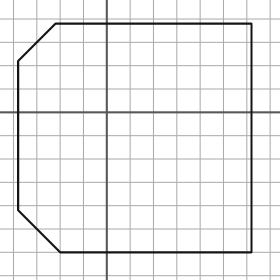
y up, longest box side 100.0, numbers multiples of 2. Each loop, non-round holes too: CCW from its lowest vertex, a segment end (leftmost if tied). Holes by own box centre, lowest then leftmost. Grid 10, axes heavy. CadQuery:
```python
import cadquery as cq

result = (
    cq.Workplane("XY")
    .moveTo(-20.0, -60.0)
    .lineTo(62.0, -60.0)
    .lineTo(62.0, 38.0)
    .lineTo(-22.0, 38.0)
    .lineTo(-38.0, 22.0)
    .lineTo(-38.0, -42.0)
    .close()
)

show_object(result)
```